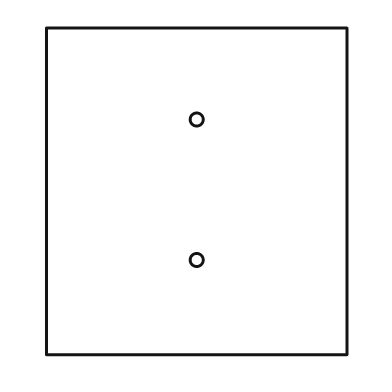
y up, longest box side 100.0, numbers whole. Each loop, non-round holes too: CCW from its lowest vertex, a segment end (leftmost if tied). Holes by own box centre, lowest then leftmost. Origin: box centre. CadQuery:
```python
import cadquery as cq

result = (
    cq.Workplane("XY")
    .moveTo(-46.0, -50.0)
    .lineTo(46.0, -50.0)
    .lineTo(46.0, 50.0)
    .lineTo(-46.0, 50.0)
    .close()
    .moveTo(0.0, -21.0)
    .circle(2.0)
    .moveTo(0.0, 22.0)
    .circle(2.0)
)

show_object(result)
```